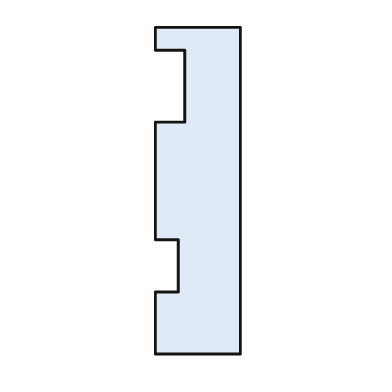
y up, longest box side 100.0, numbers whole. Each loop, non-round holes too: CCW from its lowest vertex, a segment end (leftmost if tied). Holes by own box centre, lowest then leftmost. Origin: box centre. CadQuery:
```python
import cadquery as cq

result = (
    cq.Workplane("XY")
    .moveTo(-13.0, -50.0)
    .lineTo(13.0, -50.0)
    .lineTo(13.0, 50.0)
    .lineTo(-13.0, 50.0)
    .lineTo(-13.0, 43.0)
    .lineTo(-4.0, 43.0)
    .lineTo(-4.0, 21.0)
    .lineTo(-13.0, 21.0)
    .lineTo(-13.0, -15.0)
    .lineTo(-6.0, -15.0)
    .lineTo(-6.0, -31.0)
    .lineTo(-13.0, -31.0)
    .close()
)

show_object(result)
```